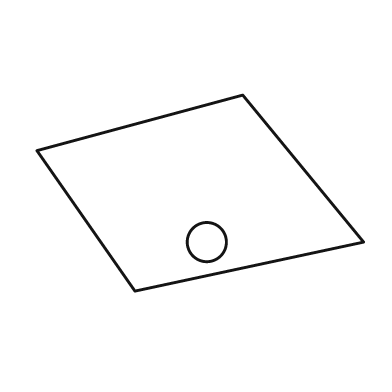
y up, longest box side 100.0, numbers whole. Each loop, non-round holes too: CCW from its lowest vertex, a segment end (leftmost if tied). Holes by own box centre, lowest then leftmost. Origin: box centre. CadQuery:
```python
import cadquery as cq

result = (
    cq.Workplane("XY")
    .moveTo(-20.0, -30.0)
    .lineTo(50.0, -15.0)
    .lineTo(13.0, 30.0)
    .lineTo(-50.0, 13.0)
    .close()
    .moveTo(2.0, -15.0)
    .circle(6.0)
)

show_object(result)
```